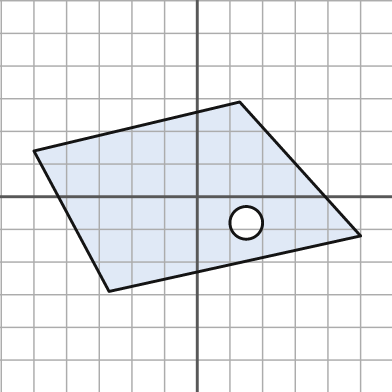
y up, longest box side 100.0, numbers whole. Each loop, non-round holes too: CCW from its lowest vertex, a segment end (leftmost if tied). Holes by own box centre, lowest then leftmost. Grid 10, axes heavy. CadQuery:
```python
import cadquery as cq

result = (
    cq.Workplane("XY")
    .moveTo(-27.0, -29.0)
    .lineTo(50.0, -12.0)
    .lineTo(13.0, 29.0)
    .lineTo(-50.0, 14.0)
    .close()
    .moveTo(15.0, -8.0)
    .circle(5.0)
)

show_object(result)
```